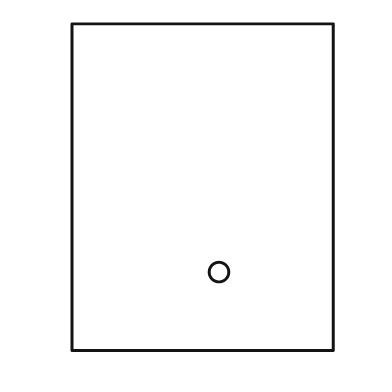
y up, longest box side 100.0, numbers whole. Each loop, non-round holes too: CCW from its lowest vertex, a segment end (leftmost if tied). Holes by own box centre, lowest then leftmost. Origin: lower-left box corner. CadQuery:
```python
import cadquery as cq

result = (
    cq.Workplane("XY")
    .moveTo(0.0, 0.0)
    .lineTo(80.0, 0.0)
    .lineTo(80.0, 100.0)
    .lineTo(0.0, 100.0)
    .close()
    .moveTo(45.0, 24.0)
    .circle(3.0)
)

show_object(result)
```